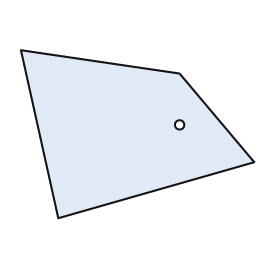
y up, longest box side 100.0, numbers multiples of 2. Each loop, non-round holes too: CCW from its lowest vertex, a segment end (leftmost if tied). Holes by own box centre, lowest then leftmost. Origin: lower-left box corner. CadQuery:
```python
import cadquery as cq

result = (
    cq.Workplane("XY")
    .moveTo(16.0, 0.0)
    .lineTo(100.0, 24.0)
    .lineTo(68.0, 62.0)
    .lineTo(0.0, 72.0)
    .close()
    .moveTo(68.0, 40.0)
    .circle(2.0)
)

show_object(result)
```